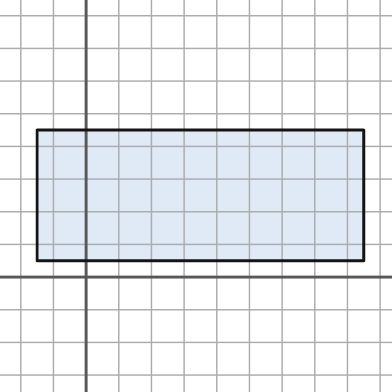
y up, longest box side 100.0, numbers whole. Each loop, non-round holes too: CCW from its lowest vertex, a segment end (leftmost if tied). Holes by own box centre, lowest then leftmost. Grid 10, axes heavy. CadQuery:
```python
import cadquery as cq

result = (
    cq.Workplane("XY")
    .moveTo(-15.0, 5.0)
    .lineTo(85.0, 5.0)
    .lineTo(85.0, 45.0)
    .lineTo(-15.0, 45.0)
    .close()
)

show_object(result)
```